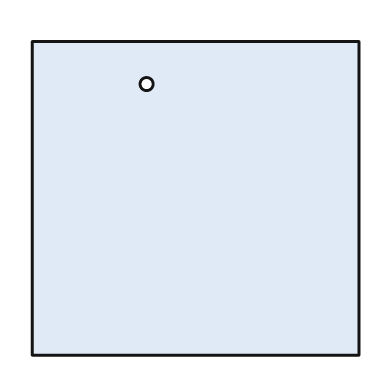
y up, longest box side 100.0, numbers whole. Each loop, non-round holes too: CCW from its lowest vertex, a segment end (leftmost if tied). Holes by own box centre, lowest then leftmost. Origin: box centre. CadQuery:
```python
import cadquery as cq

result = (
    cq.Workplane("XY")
    .moveTo(-50.0, -48.0)
    .lineTo(50.0, -48.0)
    .lineTo(50.0, 48.0)
    .lineTo(-50.0, 48.0)
    .close()
    .moveTo(-15.0, 35.0)
    .circle(2.0)
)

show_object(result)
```